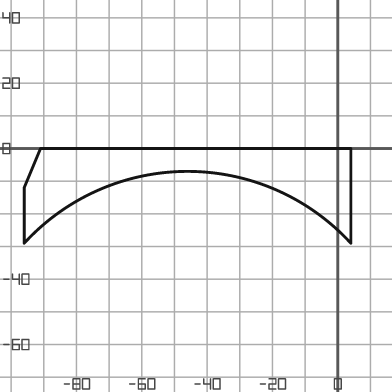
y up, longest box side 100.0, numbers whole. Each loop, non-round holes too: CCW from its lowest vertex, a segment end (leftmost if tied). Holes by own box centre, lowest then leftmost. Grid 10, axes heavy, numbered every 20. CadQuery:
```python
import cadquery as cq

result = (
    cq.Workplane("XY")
    .moveTo(-96.0, -29.0)
    .threePointArc((-46.0, -7.0), (4.0, -29.0))
    .lineTo(4.0, 0.0)
    .lineTo(-91.0, 0.0)
    .lineTo(-96.0, -12.0)
    .close()
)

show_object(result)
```